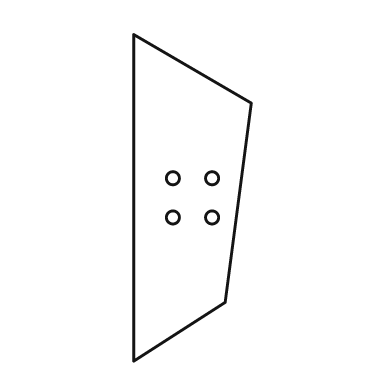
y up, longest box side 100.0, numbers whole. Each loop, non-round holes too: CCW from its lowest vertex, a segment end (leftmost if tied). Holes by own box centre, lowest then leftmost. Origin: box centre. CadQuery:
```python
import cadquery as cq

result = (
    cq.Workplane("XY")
    .moveTo(-18.0, -50.0)
    .lineTo(10.0, -32.0)
    .lineTo(18.0, 29.0)
    .lineTo(-18.0, 50.0)
    .close()
    .moveTo(-6.0, -6.0)
    .circle(2.0)
    .moveTo(6.0, -6.0)
    .circle(2.0)
    .moveTo(-6.0, 6.0)
    .circle(2.0)
    .moveTo(6.0, 6.0)
    .circle(2.0)
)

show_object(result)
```